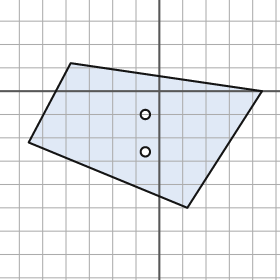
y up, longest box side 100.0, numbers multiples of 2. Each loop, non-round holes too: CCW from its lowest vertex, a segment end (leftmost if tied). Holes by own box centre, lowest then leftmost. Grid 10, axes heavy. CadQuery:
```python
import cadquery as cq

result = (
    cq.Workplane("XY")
    .moveTo(12.0, -50.0)
    .lineTo(44.0, 0.0)
    .lineTo(-38.0, 12.0)
    .lineTo(-56.0, -22.0)
    .close()
    .moveTo(-6.0, -26.0)
    .circle(2.0)
    .moveTo(-6.0, -10.0)
    .circle(2.0)
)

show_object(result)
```